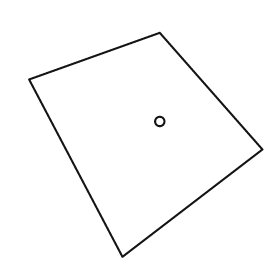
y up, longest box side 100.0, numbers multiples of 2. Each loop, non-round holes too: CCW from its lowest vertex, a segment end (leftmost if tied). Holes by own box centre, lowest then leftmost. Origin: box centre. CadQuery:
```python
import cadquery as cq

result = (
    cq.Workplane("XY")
    .moveTo(-10.0, -48.0)
    .lineTo(50.0, -2.0)
    .lineTo(6.0, 48.0)
    .lineTo(-50.0, 28.0)
    .close()
    .moveTo(6.0, 10.0)
    .circle(2.0)
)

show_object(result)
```